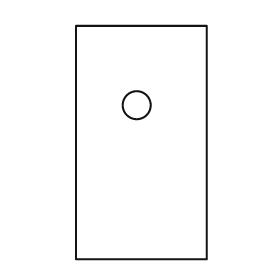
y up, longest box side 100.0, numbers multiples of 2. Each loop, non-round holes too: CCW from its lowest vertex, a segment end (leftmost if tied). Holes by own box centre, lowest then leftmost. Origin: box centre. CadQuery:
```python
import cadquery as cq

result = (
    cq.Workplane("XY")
    .moveTo(-28.0, -50.0)
    .lineTo(28.0, -50.0)
    .lineTo(28.0, 50.0)
    .lineTo(-28.0, 50.0)
    .close()
    .moveTo(-2.0, 16.0)
    .circle(6.0)
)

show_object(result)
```